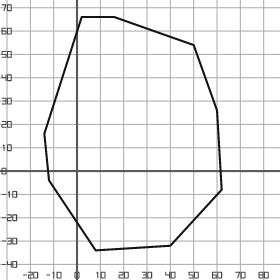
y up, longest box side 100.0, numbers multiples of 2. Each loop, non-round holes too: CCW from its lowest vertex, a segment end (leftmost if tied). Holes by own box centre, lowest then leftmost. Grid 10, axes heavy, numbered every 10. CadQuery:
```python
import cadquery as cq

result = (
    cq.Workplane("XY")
    .moveTo(8.0, -34.0)
    .lineTo(40.0, -32.0)
    .lineTo(62.0, -8.0)
    .lineTo(60.0, 26.0)
    .lineTo(50.0, 54.0)
    .lineTo(16.0, 66.0)
    .lineTo(2.0, 66.0)
    .lineTo(-14.0, 16.0)
    .lineTo(-12.0, -4.0)
    .close()
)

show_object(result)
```